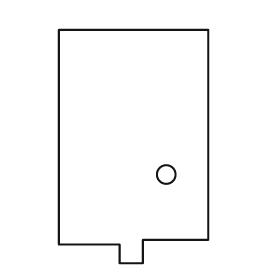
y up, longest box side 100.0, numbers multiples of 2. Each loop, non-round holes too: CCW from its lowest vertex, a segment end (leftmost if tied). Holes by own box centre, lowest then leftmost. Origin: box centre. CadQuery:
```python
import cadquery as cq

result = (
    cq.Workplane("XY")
    .moveTo(-6.0, -50.0)
    .lineTo(4.0, -50.0)
    .lineTo(4.0, -40.0)
    .lineTo(32.0, -40.0)
    .lineTo(32.0, 50.0)
    .lineTo(-32.0, 50.0)
    .lineTo(-32.0, -42.0)
    .lineTo(-6.0, -42.0)
    .close()
    .moveTo(14.0, -12.0)
    .circle(4.0)
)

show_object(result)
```